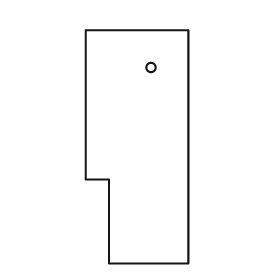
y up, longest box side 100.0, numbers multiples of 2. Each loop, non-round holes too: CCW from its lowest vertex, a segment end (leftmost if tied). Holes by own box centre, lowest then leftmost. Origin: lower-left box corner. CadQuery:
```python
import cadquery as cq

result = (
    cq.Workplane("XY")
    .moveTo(10.0, 0.0)
    .lineTo(44.0, 0.0)
    .lineTo(44.0, 100.0)
    .lineTo(0.0, 100.0)
    .lineTo(0.0, 36.0)
    .lineTo(10.0, 36.0)
    .close()
    .moveTo(28.0, 84.0)
    .circle(2.0)
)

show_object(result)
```